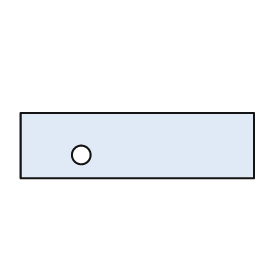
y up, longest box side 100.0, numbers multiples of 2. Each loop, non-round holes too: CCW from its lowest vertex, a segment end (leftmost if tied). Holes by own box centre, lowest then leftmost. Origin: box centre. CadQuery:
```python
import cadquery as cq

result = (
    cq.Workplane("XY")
    .moveTo(-50.0, -14.0)
    .lineTo(50.0, -14.0)
    .lineTo(50.0, 14.0)
    .lineTo(-50.0, 14.0)
    .close()
    .moveTo(-24.0, -4.0)
    .circle(4.0)
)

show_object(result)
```